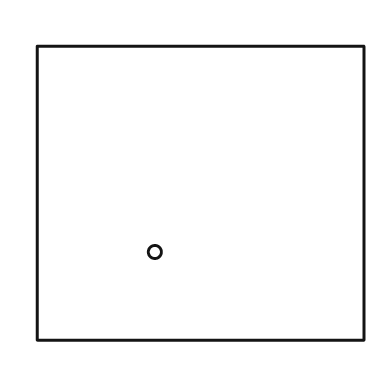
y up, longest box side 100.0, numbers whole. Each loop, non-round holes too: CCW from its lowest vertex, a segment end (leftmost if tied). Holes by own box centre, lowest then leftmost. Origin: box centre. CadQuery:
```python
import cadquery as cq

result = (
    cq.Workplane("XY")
    .moveTo(-50.0, -45.0)
    .lineTo(50.0, -45.0)
    .lineTo(50.0, 45.0)
    .lineTo(-50.0, 45.0)
    .close()
    .moveTo(-14.0, -18.0)
    .circle(2.0)
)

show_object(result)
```